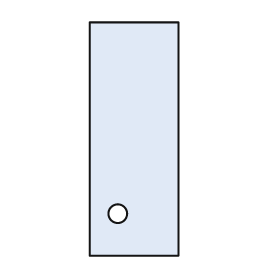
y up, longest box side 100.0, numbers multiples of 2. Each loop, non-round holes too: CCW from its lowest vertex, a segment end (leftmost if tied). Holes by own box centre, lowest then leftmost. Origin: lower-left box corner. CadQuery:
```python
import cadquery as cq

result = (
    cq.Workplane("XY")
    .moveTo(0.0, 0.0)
    .lineTo(38.0, 0.0)
    .lineTo(38.0, 100.0)
    .lineTo(0.0, 100.0)
    .close()
    .moveTo(12.0, 18.0)
    .circle(4.0)
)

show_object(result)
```